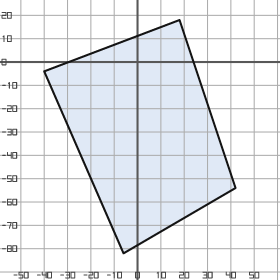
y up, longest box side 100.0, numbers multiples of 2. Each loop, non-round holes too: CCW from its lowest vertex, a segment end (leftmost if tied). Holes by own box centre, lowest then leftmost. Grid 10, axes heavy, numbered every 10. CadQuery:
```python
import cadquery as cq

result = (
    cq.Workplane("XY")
    .moveTo(-6.0, -82.0)
    .lineTo(42.0, -54.0)
    .lineTo(18.0, 18.0)
    .lineTo(-40.0, -4.0)
    .close()
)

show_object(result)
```